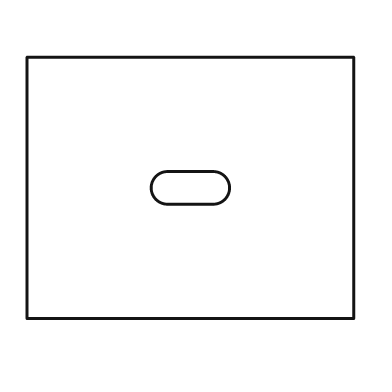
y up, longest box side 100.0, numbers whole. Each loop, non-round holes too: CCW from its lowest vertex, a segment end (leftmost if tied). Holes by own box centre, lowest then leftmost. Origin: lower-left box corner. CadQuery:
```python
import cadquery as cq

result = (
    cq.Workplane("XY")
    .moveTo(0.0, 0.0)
    .lineTo(100.0, 0.0)
    .lineTo(100.0, 80.0)
    .lineTo(0.0, 80.0)
    .close()
    .moveTo(43.0, 35.0)
    .lineTo(57.0, 35.0)
    .threePointArc((62.0, 40.0), (57.0, 45.0))
    .lineTo(43.0, 45.0)
    .threePointArc((38.0, 40.0), (43.0, 35.0))
    .close()
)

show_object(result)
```